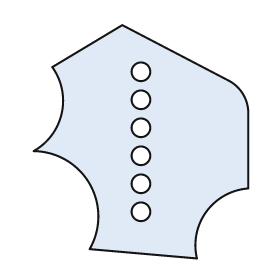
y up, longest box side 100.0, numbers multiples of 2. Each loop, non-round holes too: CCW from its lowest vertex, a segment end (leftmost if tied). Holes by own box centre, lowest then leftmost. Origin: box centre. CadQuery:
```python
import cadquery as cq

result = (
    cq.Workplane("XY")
    .moveTo(24.0, -50.0)
    .threePointArc((28.0, -30.0), (46.0, -20.0))
    .lineTo(46.0, 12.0)
    .threePointArc((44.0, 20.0), (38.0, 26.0))
    .lineTo(-8.0, 50.0)
    .lineTo(-38.0, 32.0)
    .threePointArc((-34.0, 12.0), (-46.0, -4.0))
    .threePointArc((-22.0, -18.0), (-22.0, -46.0))
    .close()
    .moveTo(0.0, -30.0)
    .circle(4.0)
    .moveTo(0.0, -18.0)
    .circle(4.0)
    .moveTo(0.0, -6.0)
    .circle(4.0)
    .moveTo(0.0, 6.0)
    .circle(4.0)
    .moveTo(0.0, 18.0)
    .circle(4.0)
    .moveTo(0.0, 30.0)
    .circle(4.0)
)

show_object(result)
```